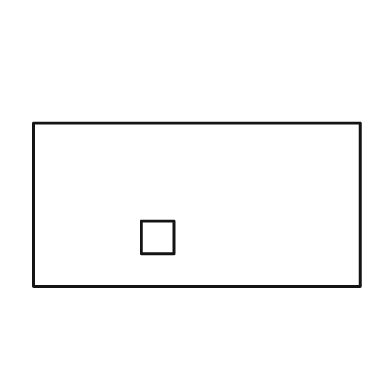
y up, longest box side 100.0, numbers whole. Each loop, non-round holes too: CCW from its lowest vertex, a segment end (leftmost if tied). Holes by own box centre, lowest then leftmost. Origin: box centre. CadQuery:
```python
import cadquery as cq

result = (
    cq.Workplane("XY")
    .moveTo(-50.0, -25.0)
    .lineTo(50.0, -25.0)
    .lineTo(50.0, 25.0)
    .lineTo(-50.0, 25.0)
    .close()
    .moveTo(-17.0, -15.0)
    .lineTo(-7.0, -15.0)
    .lineTo(-7.0, -5.0)
    .lineTo(-17.0, -5.0)
    .close()
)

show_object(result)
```